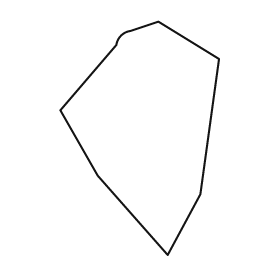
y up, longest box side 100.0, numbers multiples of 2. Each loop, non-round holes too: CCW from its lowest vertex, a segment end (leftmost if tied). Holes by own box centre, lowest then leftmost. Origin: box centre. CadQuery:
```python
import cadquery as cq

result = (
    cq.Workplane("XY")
    .moveTo(12.0, -50.0)
    .lineTo(26.0, -24.0)
    .lineTo(34.0, 34.0)
    .lineTo(8.0, 50.0)
    .lineTo(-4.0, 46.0)
    .threePointArc((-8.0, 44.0), (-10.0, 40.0))
    .lineTo(-34.0, 12.0)
    .lineTo(-18.0, -16.0)
    .close()
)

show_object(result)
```